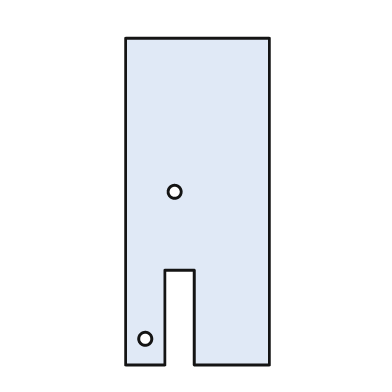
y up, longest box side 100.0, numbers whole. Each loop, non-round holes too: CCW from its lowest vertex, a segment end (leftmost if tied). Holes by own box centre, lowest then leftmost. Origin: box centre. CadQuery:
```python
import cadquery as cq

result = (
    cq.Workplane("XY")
    .moveTo(-22.0, -50.0)
    .lineTo(-10.0, -50.0)
    .lineTo(-10.0, -21.0)
    .lineTo(-1.0, -21.0)
    .lineTo(-1.0, -50.0)
    .lineTo(22.0, -50.0)
    .lineTo(22.0, 50.0)
    .lineTo(-22.0, 50.0)
    .close()
    .moveTo(-16.0, -42.0)
    .circle(2.0)
    .moveTo(-7.0, 3.0)
    .circle(2.0)
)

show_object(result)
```